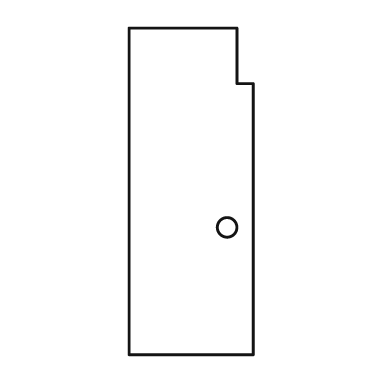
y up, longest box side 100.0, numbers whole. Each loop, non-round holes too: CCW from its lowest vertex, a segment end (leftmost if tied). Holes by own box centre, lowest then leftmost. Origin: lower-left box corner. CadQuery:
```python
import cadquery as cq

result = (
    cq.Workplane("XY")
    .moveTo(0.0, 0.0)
    .lineTo(38.0, 0.0)
    .lineTo(38.0, 83.0)
    .lineTo(33.0, 83.0)
    .lineTo(33.0, 100.0)
    .lineTo(0.0, 100.0)
    .close()
    .moveTo(30.0, 39.0)
    .circle(3.0)
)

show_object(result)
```